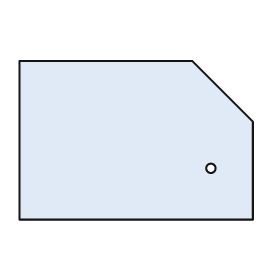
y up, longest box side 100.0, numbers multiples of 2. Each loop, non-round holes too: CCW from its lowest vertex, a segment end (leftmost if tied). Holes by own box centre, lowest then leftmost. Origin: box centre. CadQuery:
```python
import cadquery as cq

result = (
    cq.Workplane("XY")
    .moveTo(-50.0, -34.0)
    .lineTo(50.0, -34.0)
    .lineTo(50.0, 8.0)
    .lineTo(24.0, 34.0)
    .lineTo(-50.0, 34.0)
    .close()
    .moveTo(32.0, -12.0)
    .circle(2.0)
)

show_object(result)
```